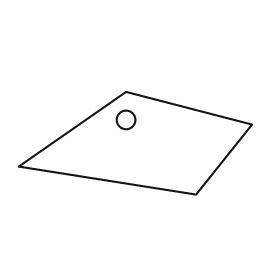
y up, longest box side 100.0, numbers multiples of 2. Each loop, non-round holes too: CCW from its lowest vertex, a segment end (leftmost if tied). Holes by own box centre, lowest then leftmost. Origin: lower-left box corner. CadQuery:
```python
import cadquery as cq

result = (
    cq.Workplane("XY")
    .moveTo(76.0, 0.0)
    .lineTo(100.0, 30.0)
    .lineTo(46.0, 44.0)
    .lineTo(0.0, 12.0)
    .close()
    .moveTo(46.0, 32.0)
    .circle(4.0)
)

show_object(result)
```